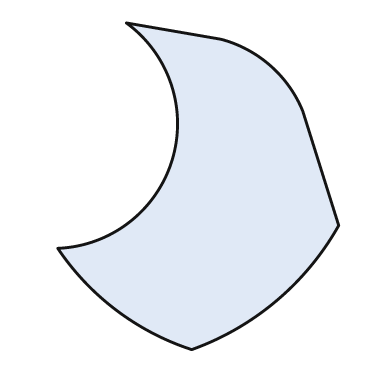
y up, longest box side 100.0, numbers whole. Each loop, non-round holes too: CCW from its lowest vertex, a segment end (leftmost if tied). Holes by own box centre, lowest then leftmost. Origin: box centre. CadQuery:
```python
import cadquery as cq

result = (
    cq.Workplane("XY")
    .moveTo(-2.0, -50.0)
    .threePointArc((24.0, -35.0), (43.0, -12.0))
    .lineTo(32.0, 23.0)
    .threePointArc((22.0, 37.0), (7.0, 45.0))
    .lineTo(-22.0, 50.0)
    .threePointArc((-8.0, 8.0), (-43.0, -19.0))
    .threePointArc((-25.0, -38.0), (-2.0, -50.0))
    .close()
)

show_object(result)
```